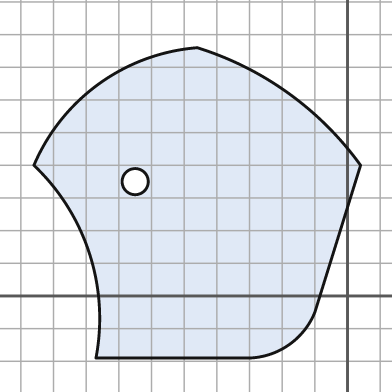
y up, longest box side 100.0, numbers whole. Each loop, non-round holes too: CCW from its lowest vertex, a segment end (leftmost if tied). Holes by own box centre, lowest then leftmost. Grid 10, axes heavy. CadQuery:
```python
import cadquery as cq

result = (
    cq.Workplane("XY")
    .moveTo(-77.0, -19.0)
    .lineTo(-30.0, -19.0)
    .threePointArc((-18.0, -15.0), (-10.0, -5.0))
    .lineTo(4.0, 40.0)
    .threePointArc((-18.0, 62.0), (-46.0, 76.0))
    .threePointArc((-76.0, 65.0), (-96.0, 40.0))
    .threePointArc((-79.0, 13.0), (-77.0, -19.0))
    .close()
    .moveTo(-65.0, 35.0)
    .circle(4.0)
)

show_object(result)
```